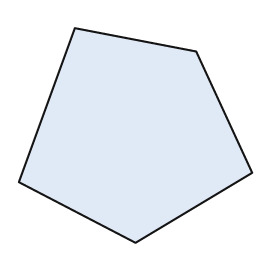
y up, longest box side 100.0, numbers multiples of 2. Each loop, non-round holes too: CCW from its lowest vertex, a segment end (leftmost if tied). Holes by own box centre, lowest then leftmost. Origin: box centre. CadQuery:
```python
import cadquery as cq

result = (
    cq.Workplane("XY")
    .moveTo(0.0, -46.0)
    .lineTo(50.0, -16.0)
    .lineTo(26.0, 36.0)
    .lineTo(-26.0, 46.0)
    .lineTo(-50.0, -20.0)
    .close()
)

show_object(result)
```